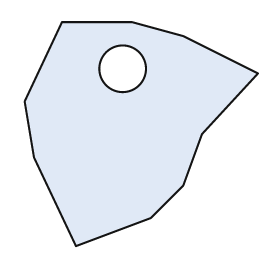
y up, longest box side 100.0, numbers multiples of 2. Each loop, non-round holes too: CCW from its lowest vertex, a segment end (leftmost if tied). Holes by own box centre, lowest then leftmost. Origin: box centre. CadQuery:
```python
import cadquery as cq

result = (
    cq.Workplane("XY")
    .moveTo(-28.0, -48.0)
    .lineTo(4.0, -36.0)
    .lineTo(18.0, -22.0)
    .lineTo(26.0, 0.0)
    .lineTo(50.0, 26.0)
    .lineTo(18.0, 42.0)
    .lineTo(-4.0, 48.0)
    .lineTo(-34.0, 48.0)
    .lineTo(-50.0, 14.0)
    .lineTo(-46.0, -10.0)
    .close()
    .moveTo(-8.0, 28.0)
    .circle(10.0)
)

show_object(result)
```